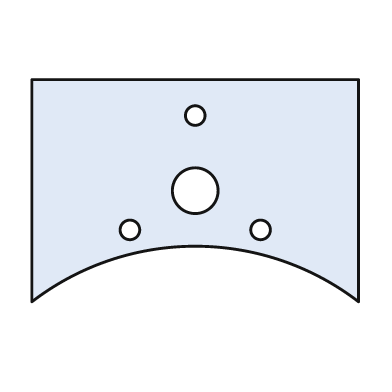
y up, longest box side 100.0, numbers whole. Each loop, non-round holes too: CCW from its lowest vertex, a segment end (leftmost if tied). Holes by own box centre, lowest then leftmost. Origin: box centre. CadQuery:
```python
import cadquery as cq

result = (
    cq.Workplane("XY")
    .moveTo(-50.0, -34.0)
    .threePointArc((0.0, -17.0), (50.0, -34.0))
    .lineTo(50.0, 34.0)
    .lineTo(-50.0, 34.0)
    .close()
    .moveTo(-20.0, -12.0)
    .circle(3.0)
    .moveTo(20.0, -12.0)
    .circle(3.0)
    .moveTo(0.0, 0.0)
    .circle(7.0)
    .moveTo(0.0, 23.0)
    .circle(3.0)
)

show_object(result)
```